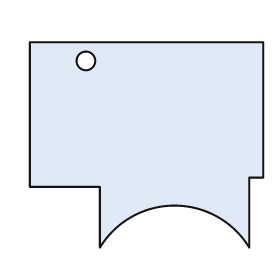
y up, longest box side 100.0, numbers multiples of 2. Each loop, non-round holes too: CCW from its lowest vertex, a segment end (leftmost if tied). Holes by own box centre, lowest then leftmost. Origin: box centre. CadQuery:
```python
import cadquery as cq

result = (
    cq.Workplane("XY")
    .moveTo(-20.0, -44.0)
    .threePointArc((12.0, -26.0), (44.0, -44.0))
    .lineTo(44.0, -14.0)
    .lineTo(50.0, -14.0)
    .lineTo(50.0, 44.0)
    .lineTo(-50.0, 44.0)
    .lineTo(-50.0, -18.0)
    .lineTo(-20.0, -18.0)
    .close()
    .moveTo(-26.0, 36.0)
    .circle(4.0)
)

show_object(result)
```